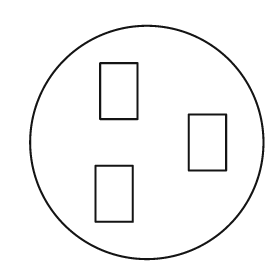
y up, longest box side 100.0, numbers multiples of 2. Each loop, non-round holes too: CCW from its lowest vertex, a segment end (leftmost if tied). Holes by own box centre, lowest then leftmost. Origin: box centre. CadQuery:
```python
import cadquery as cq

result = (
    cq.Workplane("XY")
    .moveTo(0.0, 0.0)
    .circle(50.0)
    .moveTo(-22.0, -34.0)
    .lineTo(-6.0, -34.0)
    .lineTo(-6.0, -10.0)
    .lineTo(-22.0, -10.0)
    .close()
    .moveTo(18.0, -12.0)
    .lineTo(34.0, -12.0)
    .lineTo(34.0, 12.0)
    .lineTo(18.0, 12.0)
    .close()
    .moveTo(-20.0, 10.0)
    .lineTo(-4.0, 10.0)
    .lineTo(-4.0, 34.0)
    .lineTo(-20.0, 34.0)
    .close()
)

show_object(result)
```